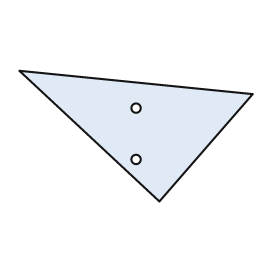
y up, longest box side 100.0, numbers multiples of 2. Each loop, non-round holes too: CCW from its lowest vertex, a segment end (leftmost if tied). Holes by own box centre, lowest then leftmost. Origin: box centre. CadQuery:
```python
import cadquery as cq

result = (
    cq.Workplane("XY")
    .moveTo(10.0, -28.0)
    .lineTo(50.0, 18.0)
    .lineTo(-50.0, 28.0)
    .close()
    .moveTo(0.0, -10.0)
    .circle(2.0)
    .moveTo(0.0, 12.0)
    .circle(2.0)
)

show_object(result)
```